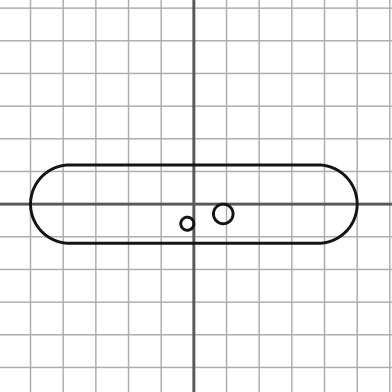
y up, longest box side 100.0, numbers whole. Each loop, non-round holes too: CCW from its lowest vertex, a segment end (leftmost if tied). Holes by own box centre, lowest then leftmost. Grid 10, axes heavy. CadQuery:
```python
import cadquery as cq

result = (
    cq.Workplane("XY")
    .moveTo(-38.0, -12.0)
    .lineTo(38.0, -12.0)
    .threePointArc((50.0, 0.0), (38.0, 12.0))
    .lineTo(-38.0, 12.0)
    .threePointArc((-50.0, 0.0), (-38.0, -12.0))
    .close()
    .moveTo(-2.0, -6.0)
    .circle(2.0)
    .moveTo(9.0, -3.0)
    .circle(3.0)
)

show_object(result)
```